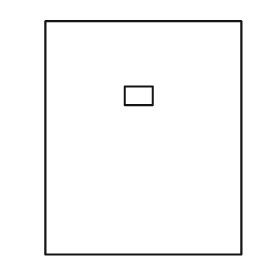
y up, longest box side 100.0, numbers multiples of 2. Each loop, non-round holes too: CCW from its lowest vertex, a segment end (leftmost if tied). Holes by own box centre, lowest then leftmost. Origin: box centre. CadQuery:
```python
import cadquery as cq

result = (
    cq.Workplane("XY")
    .moveTo(-42.0, -50.0)
    .lineTo(42.0, -50.0)
    .lineTo(42.0, 50.0)
    .lineTo(-42.0, 50.0)
    .close()
    .moveTo(-8.0, 14.0)
    .lineTo(4.0, 14.0)
    .lineTo(4.0, 22.0)
    .lineTo(-8.0, 22.0)
    .close()
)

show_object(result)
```